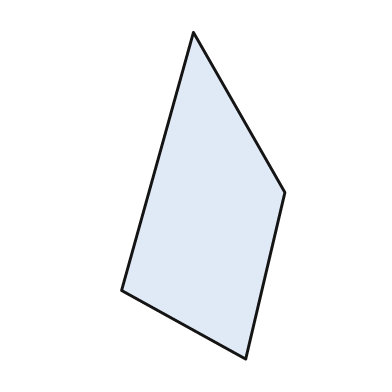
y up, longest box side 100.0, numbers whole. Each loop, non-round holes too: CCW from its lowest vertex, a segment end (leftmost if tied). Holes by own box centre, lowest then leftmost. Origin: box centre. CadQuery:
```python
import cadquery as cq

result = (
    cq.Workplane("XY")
    .moveTo(13.0, -50.0)
    .lineTo(25.0, 1.0)
    .lineTo(-3.0, 50.0)
    .lineTo(-25.0, -29.0)
    .close()
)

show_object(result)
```